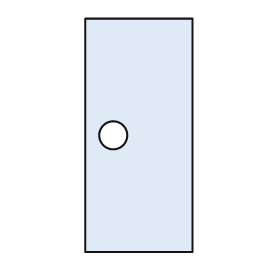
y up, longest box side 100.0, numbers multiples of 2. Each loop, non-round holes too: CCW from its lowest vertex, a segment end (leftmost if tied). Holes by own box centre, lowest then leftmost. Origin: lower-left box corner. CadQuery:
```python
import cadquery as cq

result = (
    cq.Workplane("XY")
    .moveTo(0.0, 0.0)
    .lineTo(46.0, 0.0)
    .lineTo(46.0, 100.0)
    .lineTo(0.0, 100.0)
    .close()
    .moveTo(12.0, 50.0)
    .circle(6.0)
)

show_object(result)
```